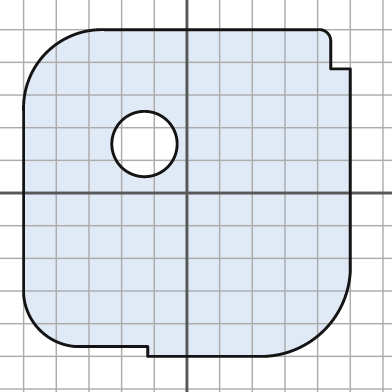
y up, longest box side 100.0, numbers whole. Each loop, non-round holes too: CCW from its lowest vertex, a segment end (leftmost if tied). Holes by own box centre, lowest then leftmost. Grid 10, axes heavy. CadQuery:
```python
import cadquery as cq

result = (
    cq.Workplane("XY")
    .moveTo(-12.0, -50.0)
    .lineTo(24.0, -50.0)
    .threePointArc((42.0, -42.0), (50.0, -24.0))
    .lineTo(50.0, 38.0)
    .lineTo(44.0, 38.0)
    .lineTo(44.0, 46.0)
    .threePointArc((43.0, 49.0), (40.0, 50.0))
    .lineTo(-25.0, 50.0)
    .threePointArc((-43.0, 43.0), (-50.0, 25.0))
    .lineTo(-50.0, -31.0)
    .threePointArc((-45.0, -42.0), (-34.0, -47.0))
    .lineTo(-12.0, -47.0)
    .close()
    .moveTo(-13.0, 15.0)
    .circle(10.0)
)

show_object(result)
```